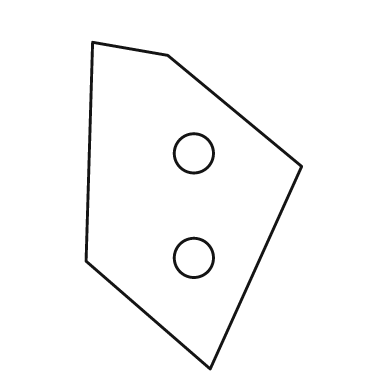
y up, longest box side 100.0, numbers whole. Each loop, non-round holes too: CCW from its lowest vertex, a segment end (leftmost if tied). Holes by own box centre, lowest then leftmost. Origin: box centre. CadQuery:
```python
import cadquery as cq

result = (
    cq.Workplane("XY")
    .moveTo(5.0, -50.0)
    .lineTo(33.0, 12.0)
    .lineTo(-8.0, 46.0)
    .lineTo(-31.0, 50.0)
    .lineTo(-33.0, -17.0)
    .close()
    .moveTo(0.0, -16.0)
    .circle(6.0)
    .moveTo(0.0, 16.0)
    .circle(6.0)
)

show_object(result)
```